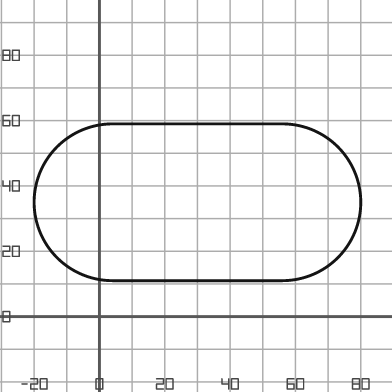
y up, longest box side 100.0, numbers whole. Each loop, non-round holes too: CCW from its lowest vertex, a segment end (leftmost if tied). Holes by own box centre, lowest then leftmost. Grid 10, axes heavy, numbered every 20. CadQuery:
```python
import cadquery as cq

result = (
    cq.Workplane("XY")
    .moveTo(4.0, 11.0)
    .lineTo(56.0, 11.0)
    .threePointArc((80.0, 35.0), (56.0, 59.0))
    .lineTo(4.0, 59.0)
    .threePointArc((-20.0, 35.0), (4.0, 11.0))
    .close()
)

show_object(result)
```